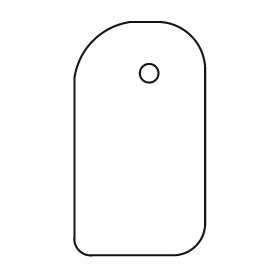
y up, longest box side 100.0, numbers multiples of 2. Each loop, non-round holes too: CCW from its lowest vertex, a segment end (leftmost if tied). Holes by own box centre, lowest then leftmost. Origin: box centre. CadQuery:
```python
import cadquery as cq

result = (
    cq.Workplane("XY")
    .moveTo(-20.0, -50.0)
    .lineTo(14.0, -50.0)
    .threePointArc((24.0, -46.0), (28.0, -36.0))
    .lineTo(28.0, 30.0)
    .threePointArc((22.0, 44.0), (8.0, 50.0))
    .lineTo(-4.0, 50.0)
    .threePointArc((-20.0, 42.0), (-28.0, 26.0))
    .lineTo(-28.0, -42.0)
    .threePointArc((-26.0, -48.0), (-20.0, -50.0))
    .close()
    .moveTo(4.0, 28.0)
    .circle(4.0)
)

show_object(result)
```